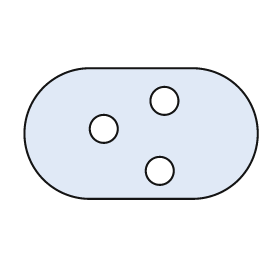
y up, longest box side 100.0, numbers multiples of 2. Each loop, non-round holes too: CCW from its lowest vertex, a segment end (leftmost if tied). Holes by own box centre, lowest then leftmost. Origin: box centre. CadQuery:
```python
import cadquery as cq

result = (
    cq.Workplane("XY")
    .moveTo(-22.0, -28.0)
    .lineTo(22.0, -28.0)
    .threePointArc((50.0, 0.0), (22.0, 28.0))
    .lineTo(-22.0, 28.0)
    .threePointArc((-50.0, 0.0), (-22.0, -28.0))
    .close()
    .moveTo(8.0, -16.0)
    .circle(6.0)
    .moveTo(-16.0, 2.0)
    .circle(6.0)
    .moveTo(10.0, 14.0)
    .circle(6.0)
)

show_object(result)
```